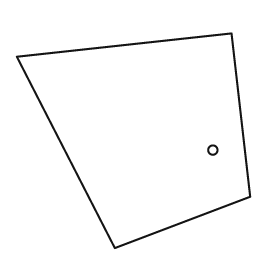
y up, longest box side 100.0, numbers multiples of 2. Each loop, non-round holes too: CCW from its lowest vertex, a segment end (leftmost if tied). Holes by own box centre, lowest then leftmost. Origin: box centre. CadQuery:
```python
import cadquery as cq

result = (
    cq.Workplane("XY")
    .moveTo(-8.0, -46.0)
    .lineTo(50.0, -24.0)
    .lineTo(42.0, 46.0)
    .lineTo(-50.0, 36.0)
    .close()
    .moveTo(34.0, -4.0)
    .circle(2.0)
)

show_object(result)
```